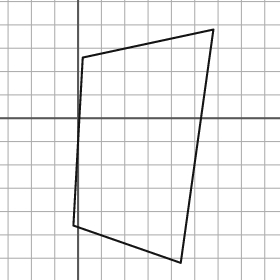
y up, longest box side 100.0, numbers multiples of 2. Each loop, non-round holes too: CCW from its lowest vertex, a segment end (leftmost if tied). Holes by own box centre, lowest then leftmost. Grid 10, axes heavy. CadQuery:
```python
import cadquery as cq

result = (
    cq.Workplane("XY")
    .moveTo(44.0, -62.0)
    .lineTo(58.0, 38.0)
    .lineTo(2.0, 26.0)
    .lineTo(-2.0, -46.0)
    .close()
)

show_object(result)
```